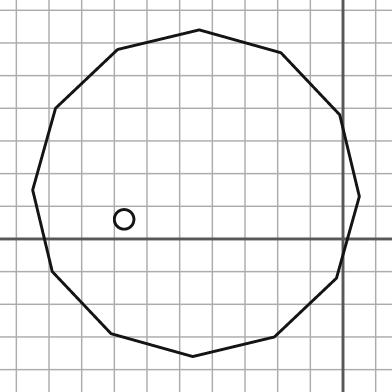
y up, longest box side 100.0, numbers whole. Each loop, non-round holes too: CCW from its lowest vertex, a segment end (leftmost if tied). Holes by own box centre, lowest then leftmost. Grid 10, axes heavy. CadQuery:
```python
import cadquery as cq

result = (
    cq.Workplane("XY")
    .moveTo(-46.0, -36.0)
    .lineTo(-21.0, -30.0)
    .lineTo(-2.0, -12.0)
    .lineTo(5.0, 13.0)
    .lineTo(-1.0, 38.0)
    .lineTo(-19.0, 57.0)
    .lineTo(-44.0, 64.0)
    .lineTo(-69.0, 58.0)
    .lineTo(-88.0, 40.0)
    .lineTo(-95.0, 15.0)
    .lineTo(-89.0, -10.0)
    .lineTo(-71.0, -29.0)
    .close()
    .moveTo(-67.0, 6.0)
    .circle(3.0)
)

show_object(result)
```